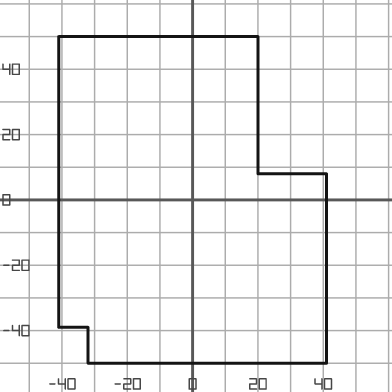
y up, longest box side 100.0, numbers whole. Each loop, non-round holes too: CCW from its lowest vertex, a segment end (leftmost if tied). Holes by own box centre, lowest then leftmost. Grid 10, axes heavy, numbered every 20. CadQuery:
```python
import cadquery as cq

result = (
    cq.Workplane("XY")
    .moveTo(-32.0, -50.0)
    .lineTo(41.0, -50.0)
    .lineTo(41.0, 8.0)
    .lineTo(20.0, 8.0)
    .lineTo(20.0, 50.0)
    .lineTo(-41.0, 50.0)
    .lineTo(-41.0, -39.0)
    .lineTo(-32.0, -39.0)
    .close()
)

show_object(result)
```